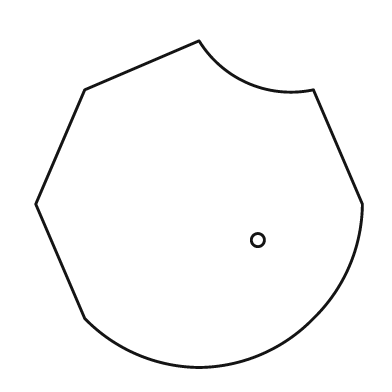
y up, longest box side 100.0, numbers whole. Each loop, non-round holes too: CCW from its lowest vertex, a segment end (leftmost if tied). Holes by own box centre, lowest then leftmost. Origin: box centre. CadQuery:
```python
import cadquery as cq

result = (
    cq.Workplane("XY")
    .moveTo(0.0, -50.0)
    .threePointArc((19.0, -46.0), (35.0, -35.0))
    .threePointArc((46.0, -19.0), (50.0, 0.0))
    .lineTo(35.0, 35.0)
    .threePointArc((15.0, 37.0), (0.0, 50.0))
    .lineTo(-35.0, 35.0)
    .lineTo(-50.0, 0.0)
    .lineTo(-35.0, -35.0)
    .threePointArc((-19.0, -46.0), (0.0, -50.0))
    .close()
    .moveTo(18.0, -11.0)
    .circle(2.0)
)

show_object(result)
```